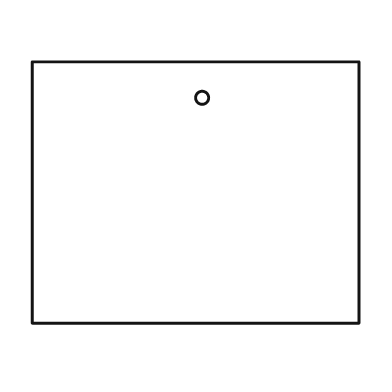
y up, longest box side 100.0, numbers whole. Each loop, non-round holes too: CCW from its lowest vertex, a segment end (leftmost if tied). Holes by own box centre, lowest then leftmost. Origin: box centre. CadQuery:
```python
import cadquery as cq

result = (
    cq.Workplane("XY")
    .moveTo(-50.0, -40.0)
    .lineTo(50.0, -40.0)
    .lineTo(50.0, 40.0)
    .lineTo(-50.0, 40.0)
    .close()
    .moveTo(2.0, 29.0)
    .circle(2.0)
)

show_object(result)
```